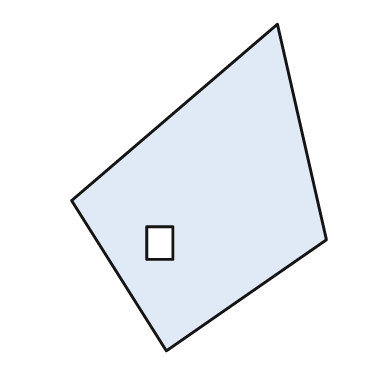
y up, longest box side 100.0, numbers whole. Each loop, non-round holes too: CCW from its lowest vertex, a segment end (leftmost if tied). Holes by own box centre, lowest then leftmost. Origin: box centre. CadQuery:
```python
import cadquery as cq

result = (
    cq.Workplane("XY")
    .moveTo(-10.0, -50.0)
    .lineTo(39.0, -16.0)
    .lineTo(24.0, 50.0)
    .lineTo(-39.0, -4.0)
    .close()
    .moveTo(-16.0, -22.0)
    .lineTo(-8.0, -22.0)
    .lineTo(-8.0, -12.0)
    .lineTo(-16.0, -12.0)
    .close()
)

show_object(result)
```